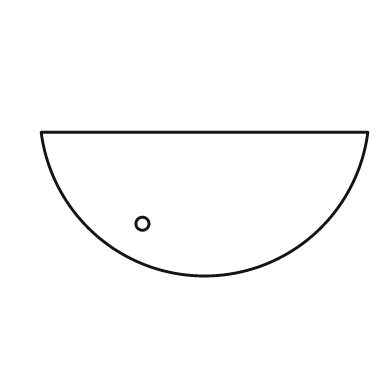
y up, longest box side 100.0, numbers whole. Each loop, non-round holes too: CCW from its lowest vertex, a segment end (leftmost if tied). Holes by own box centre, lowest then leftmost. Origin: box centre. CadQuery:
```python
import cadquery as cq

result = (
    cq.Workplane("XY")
    .moveTo(-50.0, 22.0)
    .threePointArc((0.0, -22.0), (50.0, 22.0))
    .close()
    .moveTo(-19.0, -6.0)
    .circle(2.0)
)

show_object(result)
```